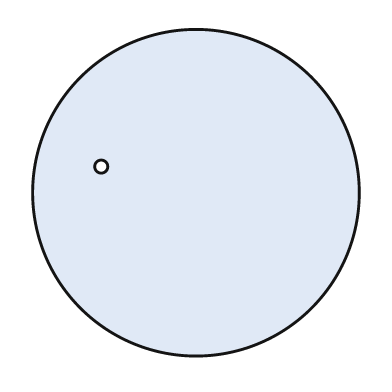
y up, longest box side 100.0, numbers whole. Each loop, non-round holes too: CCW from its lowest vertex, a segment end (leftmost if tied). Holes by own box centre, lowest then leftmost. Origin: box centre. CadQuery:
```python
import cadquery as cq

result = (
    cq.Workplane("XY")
    .moveTo(0.0, 0.0)
    .circle(50.0)
    .moveTo(-29.0, 8.0)
    .circle(2.0)
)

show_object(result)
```